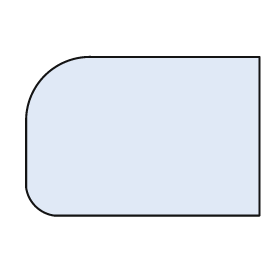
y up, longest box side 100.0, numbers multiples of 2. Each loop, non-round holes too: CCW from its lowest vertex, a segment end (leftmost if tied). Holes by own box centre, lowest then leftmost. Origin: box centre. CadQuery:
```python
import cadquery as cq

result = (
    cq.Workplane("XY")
    .moveTo(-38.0, -34.0)
    .lineTo(50.0, -34.0)
    .lineTo(50.0, 34.0)
    .lineTo(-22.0, 34.0)
    .threePointArc((-42.0, 26.0), (-50.0, 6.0))
    .lineTo(-50.0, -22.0)
    .threePointArc((-46.0, -30.0), (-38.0, -34.0))
    .close()
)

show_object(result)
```